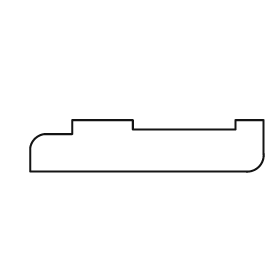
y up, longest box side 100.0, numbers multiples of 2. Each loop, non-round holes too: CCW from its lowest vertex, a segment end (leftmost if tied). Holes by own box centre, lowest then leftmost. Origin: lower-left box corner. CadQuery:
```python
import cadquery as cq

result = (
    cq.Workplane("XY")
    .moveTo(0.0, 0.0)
    .lineTo(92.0, 0.0)
    .threePointArc((98.0, 2.0), (100.0, 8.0))
    .lineTo(100.0, 22.0)
    .lineTo(88.0, 22.0)
    .lineTo(88.0, 18.0)
    .lineTo(44.0, 18.0)
    .lineTo(44.0, 22.0)
    .lineTo(18.0, 22.0)
    .lineTo(18.0, 16.0)
    .lineTo(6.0, 16.0)
    .threePointArc((2.0, 14.0), (0.0, 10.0))
    .close()
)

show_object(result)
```